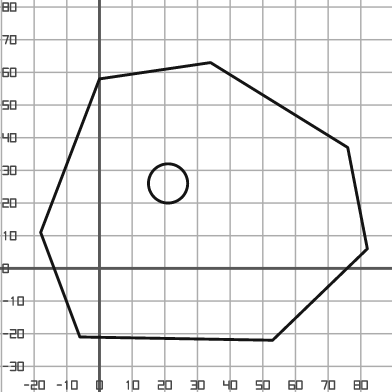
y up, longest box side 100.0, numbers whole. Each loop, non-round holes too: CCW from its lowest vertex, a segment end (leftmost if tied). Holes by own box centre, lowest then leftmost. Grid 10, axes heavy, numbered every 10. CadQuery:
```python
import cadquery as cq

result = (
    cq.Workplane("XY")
    .moveTo(53.0, -22.0)
    .lineTo(82.0, 6.0)
    .lineTo(76.0, 37.0)
    .lineTo(34.0, 63.0)
    .lineTo(0.0, 58.0)
    .lineTo(-18.0, 11.0)
    .lineTo(-6.0, -21.0)
    .close()
    .moveTo(21.0, 26.0)
    .circle(6.0)
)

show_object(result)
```